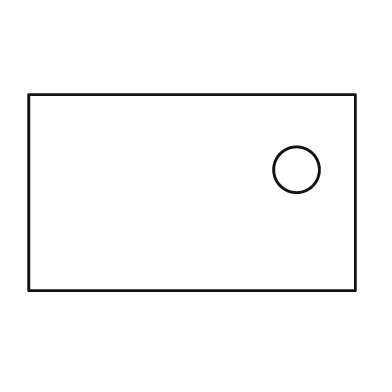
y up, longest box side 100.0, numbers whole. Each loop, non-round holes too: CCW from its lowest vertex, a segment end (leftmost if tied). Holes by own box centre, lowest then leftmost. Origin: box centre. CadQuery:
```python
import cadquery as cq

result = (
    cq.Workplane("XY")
    .moveTo(-50.0, -30.0)
    .lineTo(50.0, -30.0)
    .lineTo(50.0, 30.0)
    .lineTo(-50.0, 30.0)
    .close()
    .moveTo(32.0, 7.0)
    .circle(7.0)
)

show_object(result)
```